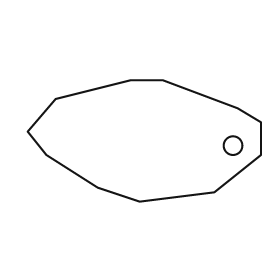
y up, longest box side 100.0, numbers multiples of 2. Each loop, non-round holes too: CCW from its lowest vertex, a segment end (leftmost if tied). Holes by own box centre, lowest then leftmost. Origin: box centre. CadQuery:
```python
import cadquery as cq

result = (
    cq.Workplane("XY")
    .moveTo(-2.0, -26.0)
    .lineTo(30.0, -22.0)
    .lineTo(50.0, -6.0)
    .lineTo(50.0, 8.0)
    .lineTo(40.0, 14.0)
    .lineTo(8.0, 26.0)
    .lineTo(-6.0, 26.0)
    .lineTo(-38.0, 18.0)
    .lineTo(-50.0, 4.0)
    .lineTo(-42.0, -6.0)
    .lineTo(-20.0, -20.0)
    .close()
    .moveTo(38.0, -2.0)
    .circle(4.0)
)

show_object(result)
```